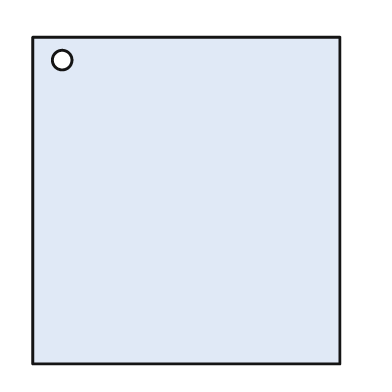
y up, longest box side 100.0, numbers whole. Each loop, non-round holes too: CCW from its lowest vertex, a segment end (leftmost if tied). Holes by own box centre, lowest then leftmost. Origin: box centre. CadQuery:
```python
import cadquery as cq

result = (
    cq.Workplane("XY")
    .moveTo(-47.0, -50.0)
    .lineTo(47.0, -50.0)
    .lineTo(47.0, 50.0)
    .lineTo(-47.0, 50.0)
    .close()
    .moveTo(-38.0, 43.0)
    .circle(3.0)
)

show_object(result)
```